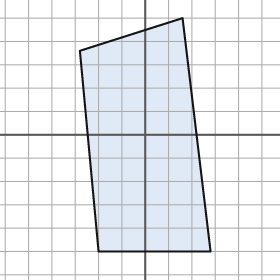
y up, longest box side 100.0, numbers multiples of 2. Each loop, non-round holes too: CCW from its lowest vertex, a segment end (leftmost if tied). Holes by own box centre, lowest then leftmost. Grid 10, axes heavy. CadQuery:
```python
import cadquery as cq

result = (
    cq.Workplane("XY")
    .moveTo(-20.0, -50.0)
    .lineTo(28.0, -50.0)
    .lineTo(16.0, 50.0)
    .lineTo(-28.0, 36.0)
    .close()
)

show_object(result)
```